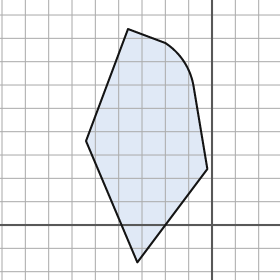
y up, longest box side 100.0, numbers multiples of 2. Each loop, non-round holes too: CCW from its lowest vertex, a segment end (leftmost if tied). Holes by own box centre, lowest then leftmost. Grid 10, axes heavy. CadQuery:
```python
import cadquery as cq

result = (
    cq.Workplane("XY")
    .moveTo(-32.0, -16.0)
    .lineTo(-2.0, 24.0)
    .lineTo(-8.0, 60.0)
    .threePointArc((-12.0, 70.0), (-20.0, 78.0))
    .lineTo(-36.0, 84.0)
    .lineTo(-54.0, 36.0)
    .close()
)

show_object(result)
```